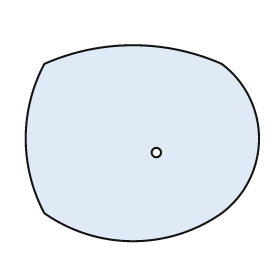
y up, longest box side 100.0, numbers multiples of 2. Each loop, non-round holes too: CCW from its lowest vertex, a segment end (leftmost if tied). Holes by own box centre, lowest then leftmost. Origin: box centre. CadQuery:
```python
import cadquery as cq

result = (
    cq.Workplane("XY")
    .moveTo(-42.0, -30.0)
    .threePointArc((-4.0, -42.0), (34.0, -30.0))
    .threePointArc((50.0, 2.0), (34.0, 34.0))
    .threePointArc((-4.0, 42.0), (-42.0, 34.0))
    .threePointArc((-50.0, 2.0), (-42.0, -30.0))
    .close()
    .moveTo(6.0, -4.0)
    .circle(2.0)
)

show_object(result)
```